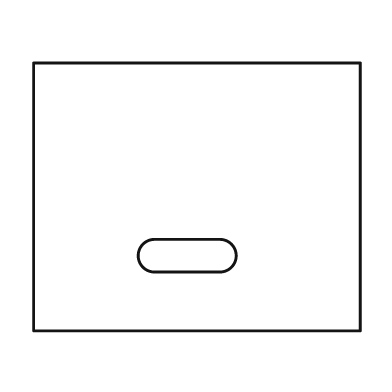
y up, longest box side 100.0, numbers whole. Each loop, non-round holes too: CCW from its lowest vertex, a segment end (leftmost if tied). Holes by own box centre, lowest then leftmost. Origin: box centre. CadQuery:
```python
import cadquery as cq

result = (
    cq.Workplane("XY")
    .moveTo(-50.0, -41.0)
    .lineTo(50.0, -41.0)
    .lineTo(50.0, 41.0)
    .lineTo(-50.0, 41.0)
    .close()
    .moveTo(-13.0, -23.0)
    .lineTo(7.0, -23.0)
    .threePointArc((12.0, -18.0), (7.0, -13.0))
    .lineTo(-13.0, -13.0)
    .threePointArc((-18.0, -18.0), (-13.0, -23.0))
    .close()
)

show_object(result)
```